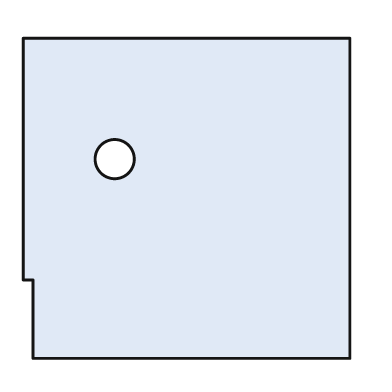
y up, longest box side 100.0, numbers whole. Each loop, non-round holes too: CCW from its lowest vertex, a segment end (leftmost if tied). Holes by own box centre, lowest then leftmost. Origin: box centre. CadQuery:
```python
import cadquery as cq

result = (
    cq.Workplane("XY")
    .moveTo(-47.0, -49.0)
    .lineTo(50.0, -49.0)
    .lineTo(50.0, 49.0)
    .lineTo(-50.0, 49.0)
    .lineTo(-50.0, -25.0)
    .lineTo(-47.0, -25.0)
    .close()
    .moveTo(-22.0, 12.0)
    .circle(6.0)
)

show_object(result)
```